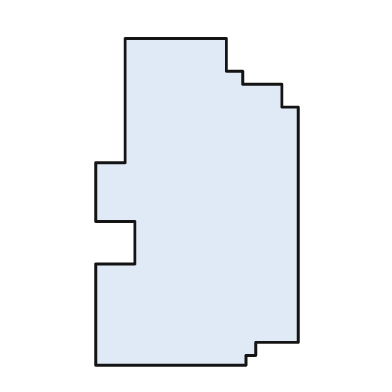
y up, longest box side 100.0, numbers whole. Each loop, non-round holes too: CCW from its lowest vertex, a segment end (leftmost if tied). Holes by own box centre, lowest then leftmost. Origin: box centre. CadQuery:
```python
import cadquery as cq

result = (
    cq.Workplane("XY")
    .moveTo(-31.0, -50.0)
    .lineTo(15.0, -50.0)
    .lineTo(15.0, -47.0)
    .lineTo(18.0, -47.0)
    .lineTo(18.0, -43.0)
    .lineTo(31.0, -43.0)
    .lineTo(31.0, 29.0)
    .lineTo(26.0, 29.0)
    .lineTo(26.0, 36.0)
    .lineTo(14.0, 36.0)
    .lineTo(14.0, 40.0)
    .lineTo(9.0, 40.0)
    .lineTo(9.0, 50.0)
    .lineTo(-22.0, 50.0)
    .lineTo(-22.0, 12.0)
    .lineTo(-31.0, 12.0)
    .lineTo(-31.0, -6.0)
    .lineTo(-19.0, -6.0)
    .lineTo(-19.0, -19.0)
    .lineTo(-31.0, -19.0)
    .close()
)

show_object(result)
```